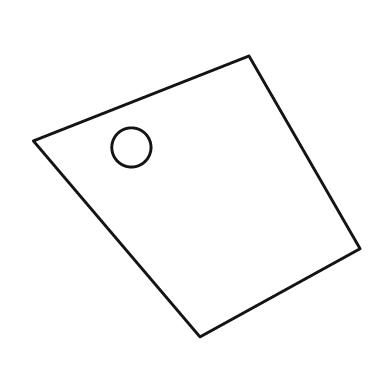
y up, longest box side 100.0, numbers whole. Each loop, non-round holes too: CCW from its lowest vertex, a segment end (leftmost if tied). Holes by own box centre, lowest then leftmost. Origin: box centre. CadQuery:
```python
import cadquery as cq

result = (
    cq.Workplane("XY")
    .moveTo(1.0, -43.0)
    .lineTo(50.0, -16.0)
    .lineTo(16.0, 43.0)
    .lineTo(-50.0, 17.0)
    .close()
    .moveTo(-20.0, 15.0)
    .circle(6.0)
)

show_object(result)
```